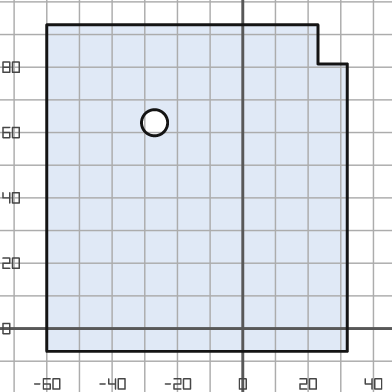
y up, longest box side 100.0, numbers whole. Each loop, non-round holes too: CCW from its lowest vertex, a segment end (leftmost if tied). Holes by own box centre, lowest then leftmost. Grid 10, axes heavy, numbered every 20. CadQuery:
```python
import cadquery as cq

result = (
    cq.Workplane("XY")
    .moveTo(-60.0, -7.0)
    .lineTo(32.0, -7.0)
    .lineTo(32.0, 81.0)
    .lineTo(23.0, 81.0)
    .lineTo(23.0, 93.0)
    .lineTo(-60.0, 93.0)
    .close()
    .moveTo(-27.0, 63.0)
    .circle(4.0)
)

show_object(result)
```